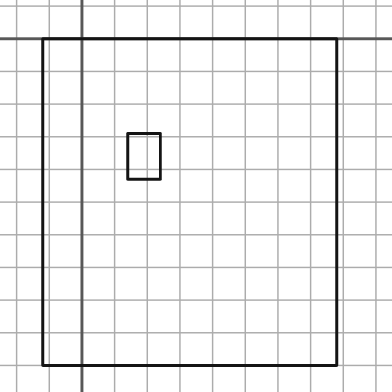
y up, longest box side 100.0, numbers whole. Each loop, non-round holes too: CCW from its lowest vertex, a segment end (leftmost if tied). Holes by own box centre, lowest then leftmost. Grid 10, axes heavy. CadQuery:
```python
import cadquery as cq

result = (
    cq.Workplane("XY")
    .moveTo(-12.0, -100.0)
    .lineTo(78.0, -100.0)
    .lineTo(78.0, 0.0)
    .lineTo(-12.0, 0.0)
    .close()
    .moveTo(14.0, -43.0)
    .lineTo(24.0, -43.0)
    .lineTo(24.0, -29.0)
    .lineTo(14.0, -29.0)
    .close()
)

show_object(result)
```